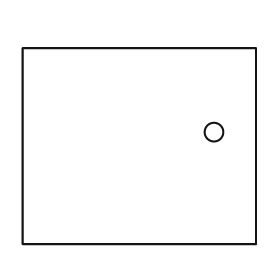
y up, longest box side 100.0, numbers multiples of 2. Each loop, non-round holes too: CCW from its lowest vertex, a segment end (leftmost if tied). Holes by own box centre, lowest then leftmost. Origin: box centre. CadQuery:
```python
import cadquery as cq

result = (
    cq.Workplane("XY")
    .moveTo(-50.0, -42.0)
    .lineTo(50.0, -42.0)
    .lineTo(50.0, 42.0)
    .lineTo(-50.0, 42.0)
    .close()
    .moveTo(32.0, 6.0)
    .circle(4.0)
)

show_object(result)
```